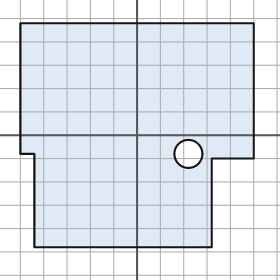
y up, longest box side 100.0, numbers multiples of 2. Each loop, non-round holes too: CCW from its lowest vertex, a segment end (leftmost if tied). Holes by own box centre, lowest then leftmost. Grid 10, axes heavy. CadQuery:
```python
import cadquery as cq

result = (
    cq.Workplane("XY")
    .moveTo(-44.0, -48.0)
    .lineTo(32.0, -48.0)
    .lineTo(32.0, -10.0)
    .lineTo(50.0, -10.0)
    .lineTo(50.0, 48.0)
    .lineTo(-50.0, 48.0)
    .lineTo(-50.0, -8.0)
    .lineTo(-44.0, -8.0)
    .close()
    .moveTo(22.0, -8.0)
    .circle(6.0)
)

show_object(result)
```